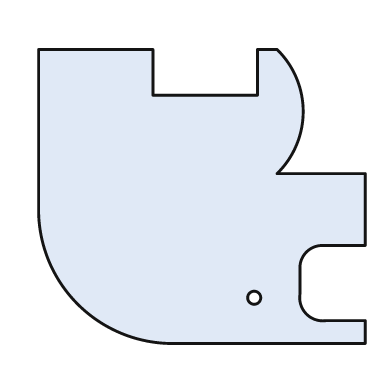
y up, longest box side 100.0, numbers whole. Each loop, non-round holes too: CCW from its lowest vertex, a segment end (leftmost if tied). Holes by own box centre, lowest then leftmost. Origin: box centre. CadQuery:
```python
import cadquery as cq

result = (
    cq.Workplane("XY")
    .moveTo(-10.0, -45.0)
    .lineTo(50.0, -45.0)
    .lineTo(50.0, -38.0)
    .lineTo(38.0, -38.0)
    .threePointArc((32.0, -36.0), (30.0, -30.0))
    .lineTo(30.0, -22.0)
    .threePointArc((32.0, -17.0), (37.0, -15.0))
    .lineTo(50.0, -15.0)
    .lineTo(50.0, 7.0)
    .lineTo(23.0, 7.0)
    .threePointArc((31.0, 26.0), (23.0, 45.0))
    .lineTo(17.0, 45.0)
    .lineTo(17.0, 31.0)
    .lineTo(-15.0, 31.0)
    .lineTo(-15.0, 45.0)
    .lineTo(-50.0, 45.0)
    .lineTo(-50.0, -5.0)
    .threePointArc((-38.0, -33.0), (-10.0, -45.0))
    .close()
    .moveTo(16.0, -31.0)
    .circle(2.0)
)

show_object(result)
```